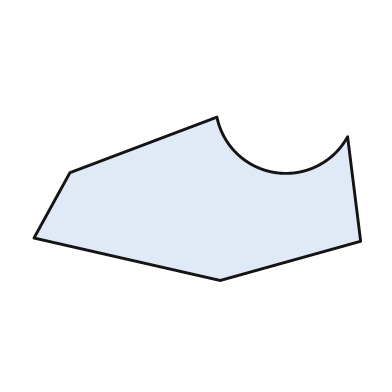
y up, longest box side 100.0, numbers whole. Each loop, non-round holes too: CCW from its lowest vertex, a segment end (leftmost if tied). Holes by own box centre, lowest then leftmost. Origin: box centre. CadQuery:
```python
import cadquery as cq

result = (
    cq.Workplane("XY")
    .moveTo(7.0, -25.0)
    .lineTo(50.0, -13.0)
    .lineTo(46.0, 19.0)
    .threePointArc((24.0, 8.0), (6.0, 25.0))
    .lineTo(-39.0, 8.0)
    .lineTo(-50.0, -12.0)
    .close()
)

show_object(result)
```